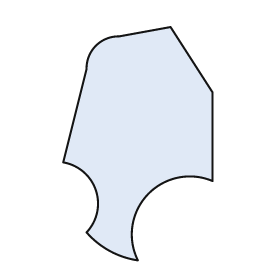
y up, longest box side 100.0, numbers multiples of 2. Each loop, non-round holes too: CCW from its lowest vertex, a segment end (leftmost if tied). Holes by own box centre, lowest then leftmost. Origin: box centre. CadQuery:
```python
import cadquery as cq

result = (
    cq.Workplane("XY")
    .moveTo(0.0, -50.0)
    .threePointArc((4.0, -22.0), (32.0, -16.0))
    .lineTo(32.0, 22.0)
    .lineTo(14.0, 50.0)
    .lineTo(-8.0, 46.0)
    .threePointArc((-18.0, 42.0), (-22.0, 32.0))
    .lineTo(-32.0, -8.0)
    .threePointArc((-18.0, -20.0), (-22.0, -38.0))
    .threePointArc((-12.0, -46.0), (0.0, -50.0))
    .close()
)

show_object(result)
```